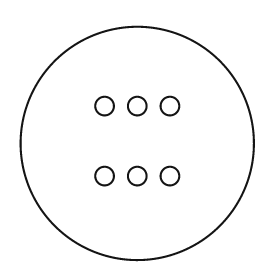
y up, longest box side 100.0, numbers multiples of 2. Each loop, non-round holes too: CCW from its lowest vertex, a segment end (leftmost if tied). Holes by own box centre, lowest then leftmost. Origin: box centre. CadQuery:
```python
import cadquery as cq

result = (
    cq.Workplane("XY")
    .moveTo(0.0, 0.0)
    .circle(50.0)
    .moveTo(-14.0, -14.0)
    .circle(4.0)
    .moveTo(0.0, -14.0)
    .circle(4.0)
    .moveTo(14.0, -14.0)
    .circle(4.0)
    .moveTo(-14.0, 16.0)
    .circle(4.0)
    .moveTo(0.0, 16.0)
    .circle(4.0)
    .moveTo(14.0, 16.0)
    .circle(4.0)
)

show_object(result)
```